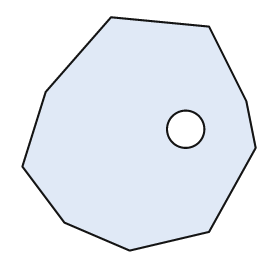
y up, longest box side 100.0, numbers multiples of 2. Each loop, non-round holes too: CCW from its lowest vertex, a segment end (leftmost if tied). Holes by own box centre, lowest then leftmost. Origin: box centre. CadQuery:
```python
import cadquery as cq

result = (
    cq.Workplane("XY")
    .moveTo(-4.0, -50.0)
    .lineTo(30.0, -42.0)
    .lineTo(50.0, -6.0)
    .lineTo(46.0, 14.0)
    .lineTo(30.0, 46.0)
    .lineTo(-12.0, 50.0)
    .lineTo(-40.0, 18.0)
    .lineTo(-50.0, -14.0)
    .lineTo(-32.0, -38.0)
    .close()
    .moveTo(20.0, 2.0)
    .circle(8.0)
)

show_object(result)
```